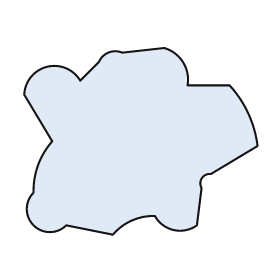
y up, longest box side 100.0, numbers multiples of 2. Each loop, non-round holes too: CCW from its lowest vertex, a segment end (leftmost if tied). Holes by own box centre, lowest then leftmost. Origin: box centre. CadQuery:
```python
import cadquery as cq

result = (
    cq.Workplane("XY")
    .moveTo(-12.0, -40.0)
    .threePointArc((-4.0, -34.0), (6.0, -32.0))
    .threePointArc((14.0, -38.0), (24.0, -36.0))
    .lineTo(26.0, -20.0)
    .threePointArc((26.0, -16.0), (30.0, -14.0))
    .lineTo(50.0, -2.0)
    .threePointArc((46.0, 12.0), (38.0, 24.0))
    .lineTo(20.0, 24.0)
    .threePointArc((18.0, 34.0), (10.0, 40.0))
    .lineTo(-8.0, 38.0)
    .threePointArc((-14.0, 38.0), (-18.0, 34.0))
    .lineTo(-26.0, 26.0)
    .threePointArc((-40.0, 32.0), (-50.0, 20.0))
    .lineTo(-38.0, 0.0)
    .threePointArc((-44.0, -10.0), (-46.0, -22.0))
    .threePointArc((-46.0, -36.0), (-32.0, -36.0))
    .close()
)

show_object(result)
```